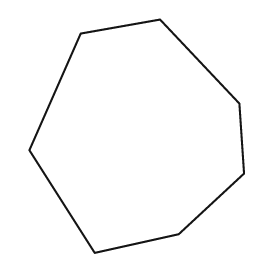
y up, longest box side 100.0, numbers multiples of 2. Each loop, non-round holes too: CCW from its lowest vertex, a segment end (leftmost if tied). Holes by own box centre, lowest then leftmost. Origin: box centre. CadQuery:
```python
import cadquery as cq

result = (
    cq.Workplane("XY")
    .moveTo(-18.0, -50.0)
    .lineTo(18.0, -42.0)
    .lineTo(46.0, -16.0)
    .lineTo(44.0, 14.0)
    .lineTo(10.0, 50.0)
    .lineTo(-24.0, 44.0)
    .lineTo(-46.0, -6.0)
    .close()
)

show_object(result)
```